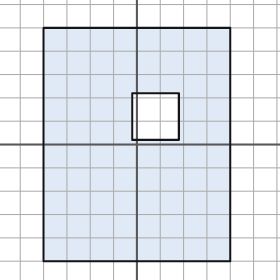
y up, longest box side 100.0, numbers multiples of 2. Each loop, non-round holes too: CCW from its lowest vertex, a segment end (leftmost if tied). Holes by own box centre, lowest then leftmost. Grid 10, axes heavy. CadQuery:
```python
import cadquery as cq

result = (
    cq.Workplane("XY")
    .moveTo(-40.0, -50.0)
    .lineTo(40.0, -50.0)
    .lineTo(40.0, 50.0)
    .lineTo(-40.0, 50.0)
    .close()
    .moveTo(-2.0, 2.0)
    .lineTo(18.0, 2.0)
    .lineTo(18.0, 22.0)
    .lineTo(-2.0, 22.0)
    .close()
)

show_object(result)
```